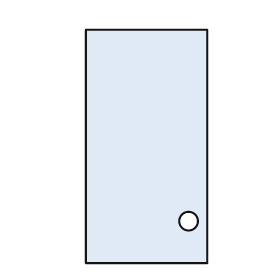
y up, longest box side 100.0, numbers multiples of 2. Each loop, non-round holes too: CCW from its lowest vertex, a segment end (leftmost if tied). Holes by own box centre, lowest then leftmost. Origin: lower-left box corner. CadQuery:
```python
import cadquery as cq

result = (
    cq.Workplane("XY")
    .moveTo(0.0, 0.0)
    .lineTo(52.0, 0.0)
    .lineTo(52.0, 100.0)
    .lineTo(0.0, 100.0)
    .close()
    .moveTo(44.0, 18.0)
    .circle(4.0)
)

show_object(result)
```